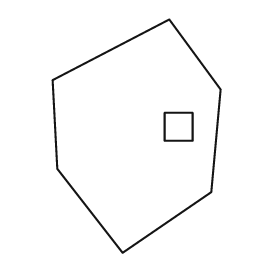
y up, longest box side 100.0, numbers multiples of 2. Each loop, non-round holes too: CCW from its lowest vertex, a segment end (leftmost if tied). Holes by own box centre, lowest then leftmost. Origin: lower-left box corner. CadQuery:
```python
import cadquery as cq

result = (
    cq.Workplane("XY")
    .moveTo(30.0, 0.0)
    .lineTo(68.0, 26.0)
    .lineTo(72.0, 70.0)
    .lineTo(50.0, 100.0)
    .lineTo(0.0, 74.0)
    .lineTo(2.0, 36.0)
    .close()
    .moveTo(48.0, 48.0)
    .lineTo(60.0, 48.0)
    .lineTo(60.0, 60.0)
    .lineTo(48.0, 60.0)
    .close()
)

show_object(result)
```